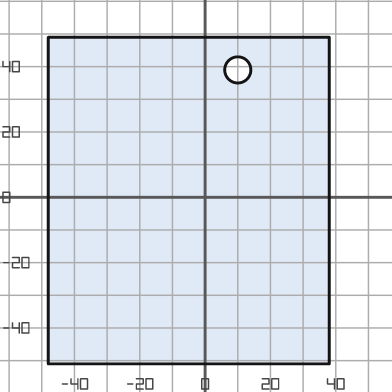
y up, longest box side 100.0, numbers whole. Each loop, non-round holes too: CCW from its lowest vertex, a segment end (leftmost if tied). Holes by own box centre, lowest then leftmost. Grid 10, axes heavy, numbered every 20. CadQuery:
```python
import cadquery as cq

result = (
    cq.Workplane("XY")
    .moveTo(-48.0, -51.0)
    .lineTo(38.0, -51.0)
    .lineTo(38.0, 49.0)
    .lineTo(-48.0, 49.0)
    .close()
    .moveTo(10.0, 39.0)
    .circle(4.0)
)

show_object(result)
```